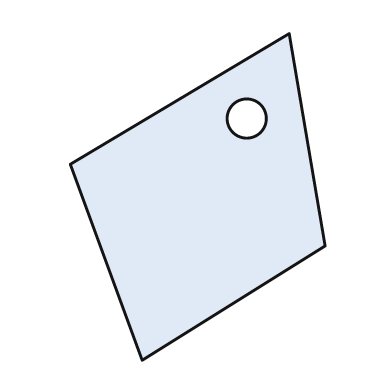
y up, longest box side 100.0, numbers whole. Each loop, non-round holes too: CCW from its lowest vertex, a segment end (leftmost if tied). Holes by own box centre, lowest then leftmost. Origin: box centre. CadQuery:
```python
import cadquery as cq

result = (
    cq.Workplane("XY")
    .moveTo(-17.0, -50.0)
    .lineTo(39.0, -15.0)
    .lineTo(28.0, 50.0)
    .lineTo(-39.0, 10.0)
    .close()
    .moveTo(15.0, 24.0)
    .circle(6.0)
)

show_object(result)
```